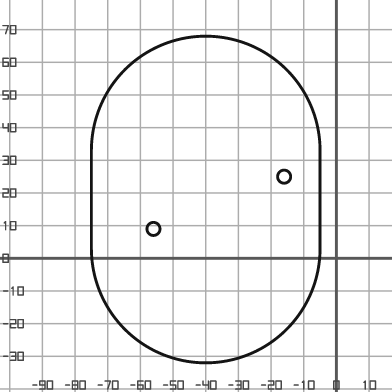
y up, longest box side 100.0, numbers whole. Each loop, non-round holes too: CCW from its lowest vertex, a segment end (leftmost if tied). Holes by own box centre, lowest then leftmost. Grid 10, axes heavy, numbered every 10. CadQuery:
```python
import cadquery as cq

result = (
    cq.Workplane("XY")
    .moveTo(-75.0, 3.0)
    .threePointArc((-40.0, -32.0), (-5.0, 3.0))
    .lineTo(-5.0, 33.0)
    .threePointArc((-40.0, 68.0), (-75.0, 33.0))
    .close()
    .moveTo(-56.0, 9.0)
    .circle(2.0)
    .moveTo(-16.0, 25.0)
    .circle(2.0)
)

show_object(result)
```